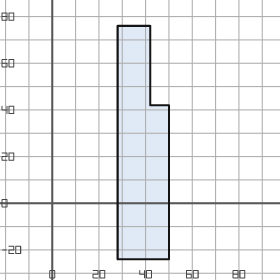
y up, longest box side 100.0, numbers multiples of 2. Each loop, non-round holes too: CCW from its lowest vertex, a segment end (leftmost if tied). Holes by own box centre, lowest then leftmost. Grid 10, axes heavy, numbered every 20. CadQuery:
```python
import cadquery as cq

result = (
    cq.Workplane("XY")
    .moveTo(28.0, -24.0)
    .lineTo(50.0, -24.0)
    .lineTo(50.0, 42.0)
    .lineTo(42.0, 42.0)
    .lineTo(42.0, 76.0)
    .lineTo(28.0, 76.0)
    .close()
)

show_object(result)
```